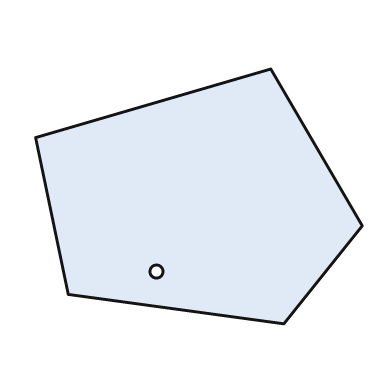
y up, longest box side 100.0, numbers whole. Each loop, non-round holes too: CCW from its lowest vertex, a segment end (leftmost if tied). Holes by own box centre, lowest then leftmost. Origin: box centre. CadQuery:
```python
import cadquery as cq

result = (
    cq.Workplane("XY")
    .moveTo(26.0, -39.0)
    .lineTo(50.0, -9.0)
    .lineTo(22.0, 39.0)
    .lineTo(-50.0, 18.0)
    .lineTo(-40.0, -30.0)
    .close()
    .moveTo(-13.0, -23.0)
    .circle(2.0)
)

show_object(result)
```